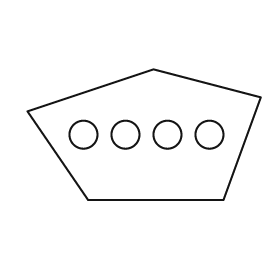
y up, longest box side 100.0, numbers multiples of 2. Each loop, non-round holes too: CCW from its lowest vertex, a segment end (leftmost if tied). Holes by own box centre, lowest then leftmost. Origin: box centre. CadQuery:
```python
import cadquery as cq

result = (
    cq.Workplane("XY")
    .moveTo(-24.0, -28.0)
    .lineTo(34.0, -28.0)
    .lineTo(50.0, 16.0)
    .lineTo(4.0, 28.0)
    .lineTo(-50.0, 10.0)
    .close()
    .moveTo(-26.0, 0.0)
    .circle(6.0)
    .moveTo(-8.0, 0.0)
    .circle(6.0)
    .moveTo(10.0, 0.0)
    .circle(6.0)
    .moveTo(28.0, 0.0)
    .circle(6.0)
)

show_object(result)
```